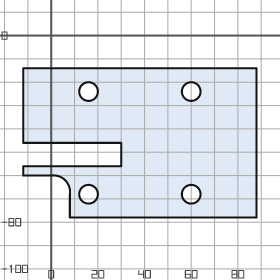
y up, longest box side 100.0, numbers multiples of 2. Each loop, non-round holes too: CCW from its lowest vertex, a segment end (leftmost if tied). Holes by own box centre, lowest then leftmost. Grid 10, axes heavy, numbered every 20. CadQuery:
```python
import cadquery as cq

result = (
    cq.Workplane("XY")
    .moveTo(8.0, -78.0)
    .lineTo(88.0, -78.0)
    .lineTo(88.0, -14.0)
    .lineTo(-12.0, -14.0)
    .lineTo(-12.0, -46.0)
    .lineTo(30.0, -46.0)
    .lineTo(30.0, -56.0)
    .lineTo(-12.0, -56.0)
    .lineTo(-12.0, -60.0)
    .lineTo(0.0, -60.0)
    .threePointArc((6.0, -62.0), (8.0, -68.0))
    .close()
    .moveTo(16.0, -68.0)
    .circle(4.0)
    .moveTo(60.0, -68.0)
    .circle(4.0)
    .moveTo(16.0, -24.0)
    .circle(4.0)
    .moveTo(60.0, -24.0)
    .circle(4.0)
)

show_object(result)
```